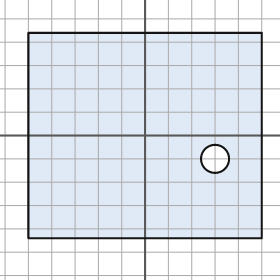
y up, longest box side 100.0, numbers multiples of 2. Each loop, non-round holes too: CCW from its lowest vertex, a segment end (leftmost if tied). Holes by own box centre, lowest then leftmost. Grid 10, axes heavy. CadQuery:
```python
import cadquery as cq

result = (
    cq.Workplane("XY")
    .moveTo(-50.0, -44.0)
    .lineTo(50.0, -44.0)
    .lineTo(50.0, 44.0)
    .lineTo(-50.0, 44.0)
    .close()
    .moveTo(30.0, -10.0)
    .circle(6.0)
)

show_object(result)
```